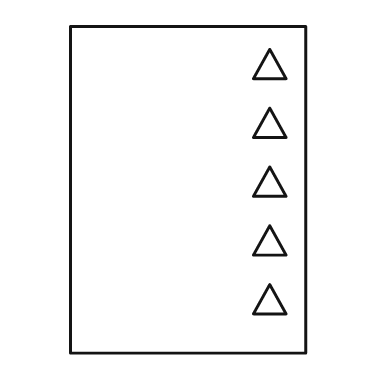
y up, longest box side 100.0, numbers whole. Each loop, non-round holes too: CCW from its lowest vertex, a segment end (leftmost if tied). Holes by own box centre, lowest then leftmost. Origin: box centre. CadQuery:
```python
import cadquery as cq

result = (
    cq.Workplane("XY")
    .moveTo(-36.0, -50.0)
    .lineTo(36.0, -50.0)
    .lineTo(36.0, 50.0)
    .lineTo(-36.0, 50.0)
    .close()
    .moveTo(20.0, -38.0)
    .lineTo(30.0, -38.0)
    .lineTo(25.0, -29.0)
    .close()
    .moveTo(20.0, -20.0)
    .lineTo(30.0, -20.0)
    .lineTo(25.0, -11.0)
    .close()
    .moveTo(20.0, -2.0)
    .lineTo(30.0, -2.0)
    .lineTo(25.0, 7.0)
    .close()
    .moveTo(20.0, 16.0)
    .lineTo(30.0, 16.0)
    .lineTo(25.0, 25.0)
    .close()
    .moveTo(20.0, 34.0)
    .lineTo(30.0, 34.0)
    .lineTo(25.0, 43.0)
    .close()
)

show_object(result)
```